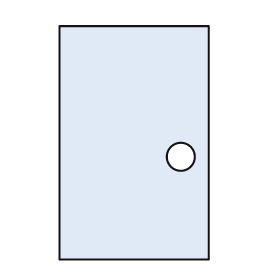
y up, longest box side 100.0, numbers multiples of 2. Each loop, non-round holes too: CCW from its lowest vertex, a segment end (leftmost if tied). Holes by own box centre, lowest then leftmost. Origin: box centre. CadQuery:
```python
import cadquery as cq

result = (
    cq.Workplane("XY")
    .moveTo(-32.0, -50.0)
    .lineTo(32.0, -50.0)
    .lineTo(32.0, 50.0)
    .lineTo(-32.0, 50.0)
    .close()
    .moveTo(20.0, -6.0)
    .circle(6.0)
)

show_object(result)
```